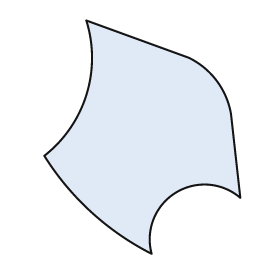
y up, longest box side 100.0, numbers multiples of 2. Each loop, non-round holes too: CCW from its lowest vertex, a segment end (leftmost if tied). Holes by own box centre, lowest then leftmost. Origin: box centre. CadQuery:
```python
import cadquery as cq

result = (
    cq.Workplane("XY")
    .moveTo(4.0, -50.0)
    .threePointArc((14.0, -24.0), (42.0, -26.0))
    .lineTo(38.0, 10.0)
    .threePointArc((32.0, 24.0), (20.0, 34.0))
    .lineTo(-24.0, 50.0)
    .threePointArc((-24.0, 18.0), (-42.0, -8.0))
    .threePointArc((-22.0, -32.0), (4.0, -50.0))
    .close()
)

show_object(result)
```